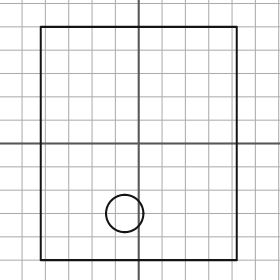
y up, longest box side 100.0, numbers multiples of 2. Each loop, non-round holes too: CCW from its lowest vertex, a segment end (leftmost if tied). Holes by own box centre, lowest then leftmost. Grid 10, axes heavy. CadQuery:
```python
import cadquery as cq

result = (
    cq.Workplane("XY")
    .moveTo(-42.0, -50.0)
    .lineTo(42.0, -50.0)
    .lineTo(42.0, 50.0)
    .lineTo(-42.0, 50.0)
    .close()
    .moveTo(-6.0, -30.0)
    .circle(8.0)
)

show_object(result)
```